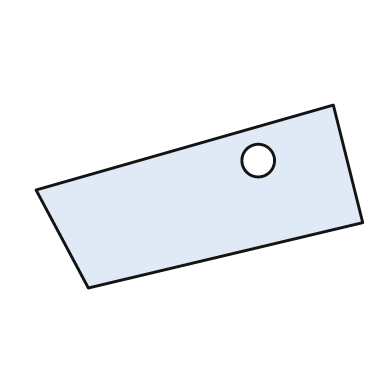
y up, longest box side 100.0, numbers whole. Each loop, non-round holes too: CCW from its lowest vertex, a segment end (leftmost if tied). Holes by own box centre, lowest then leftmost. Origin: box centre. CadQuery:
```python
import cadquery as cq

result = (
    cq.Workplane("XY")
    .moveTo(-34.0, -28.0)
    .lineTo(50.0, -8.0)
    .lineTo(41.0, 28.0)
    .lineTo(-50.0, 2.0)
    .close()
    .moveTo(18.0, 11.0)
    .circle(5.0)
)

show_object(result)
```